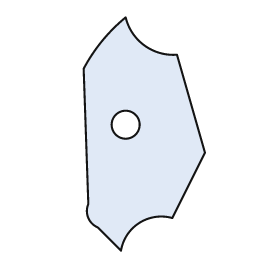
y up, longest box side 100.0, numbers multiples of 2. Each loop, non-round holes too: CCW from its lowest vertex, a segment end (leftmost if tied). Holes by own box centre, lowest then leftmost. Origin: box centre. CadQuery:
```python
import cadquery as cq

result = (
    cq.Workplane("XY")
    .moveTo(-10.0, -50.0)
    .threePointArc((-2.0, -38.0), (12.0, -36.0))
    .lineTo(26.0, -8.0)
    .lineTo(14.0, 34.0)
    .threePointArc((0.0, 38.0), (-8.0, 50.0))
    .threePointArc((-18.0, 40.0), (-26.0, 28.0))
    .lineTo(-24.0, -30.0)
    .threePointArc((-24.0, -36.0), (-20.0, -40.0))
    .close()
    .moveTo(-8.0, 4.0)
    .circle(6.0)
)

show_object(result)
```